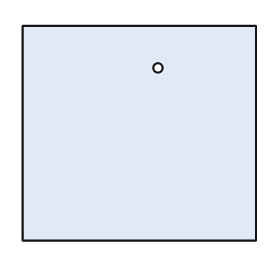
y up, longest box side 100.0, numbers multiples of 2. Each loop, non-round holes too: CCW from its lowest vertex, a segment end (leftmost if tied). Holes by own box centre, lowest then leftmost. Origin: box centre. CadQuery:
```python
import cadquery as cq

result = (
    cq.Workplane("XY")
    .moveTo(-50.0, -46.0)
    .lineTo(50.0, -46.0)
    .lineTo(50.0, 46.0)
    .lineTo(-50.0, 46.0)
    .close()
    .moveTo(8.0, 28.0)
    .circle(2.0)
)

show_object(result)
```